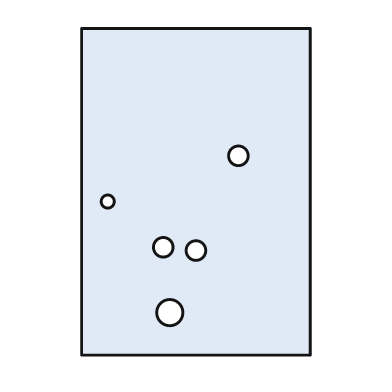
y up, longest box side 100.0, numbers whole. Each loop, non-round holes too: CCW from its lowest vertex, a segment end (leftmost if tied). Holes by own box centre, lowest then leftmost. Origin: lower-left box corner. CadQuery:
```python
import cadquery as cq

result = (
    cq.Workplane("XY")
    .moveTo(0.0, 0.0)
    .lineTo(70.0, 0.0)
    .lineTo(70.0, 100.0)
    .lineTo(0.0, 100.0)
    .close()
    .moveTo(27.0, 13.0)
    .circle(4.0)
    .moveTo(35.0, 32.0)
    .circle(3.0)
    .moveTo(25.0, 33.0)
    .circle(3.0)
    .moveTo(8.0, 47.0)
    .circle(2.0)
    .moveTo(48.0, 61.0)
    .circle(3.0)
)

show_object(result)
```